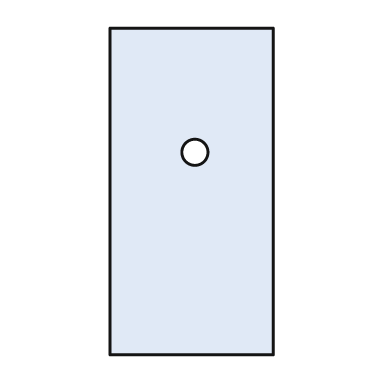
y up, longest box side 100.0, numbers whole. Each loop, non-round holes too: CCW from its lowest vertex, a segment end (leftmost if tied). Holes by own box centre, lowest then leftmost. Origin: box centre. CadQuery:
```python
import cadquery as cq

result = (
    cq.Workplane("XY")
    .moveTo(-25.0, -50.0)
    .lineTo(25.0, -50.0)
    .lineTo(25.0, 50.0)
    .lineTo(-25.0, 50.0)
    .close()
    .moveTo(1.0, 12.0)
    .circle(4.0)
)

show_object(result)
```